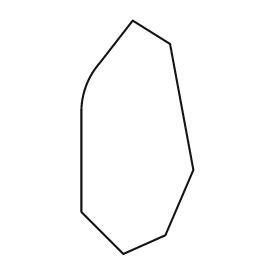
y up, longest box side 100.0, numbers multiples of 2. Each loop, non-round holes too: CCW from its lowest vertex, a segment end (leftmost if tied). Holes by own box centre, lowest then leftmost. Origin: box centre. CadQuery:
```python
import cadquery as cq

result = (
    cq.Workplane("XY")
    .moveTo(-6.0, -50.0)
    .lineTo(12.0, -42.0)
    .lineTo(24.0, -14.0)
    .lineTo(14.0, 40.0)
    .lineTo(-2.0, 50.0)
    .lineTo(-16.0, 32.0)
    .threePointArc((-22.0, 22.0), (-24.0, 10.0))
    .lineTo(-24.0, -32.0)
    .close()
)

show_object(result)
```